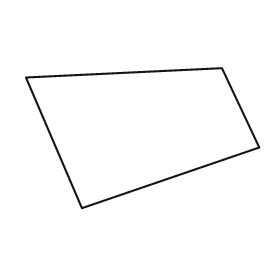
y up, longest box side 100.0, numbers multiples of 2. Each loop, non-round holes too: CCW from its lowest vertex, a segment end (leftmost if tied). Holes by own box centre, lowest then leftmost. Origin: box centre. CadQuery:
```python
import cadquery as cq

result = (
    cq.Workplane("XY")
    .moveTo(-26.0, -30.0)
    .lineTo(50.0, -4.0)
    .lineTo(34.0, 30.0)
    .lineTo(-50.0, 26.0)
    .close()
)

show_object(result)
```